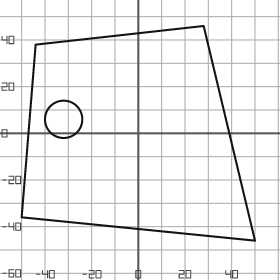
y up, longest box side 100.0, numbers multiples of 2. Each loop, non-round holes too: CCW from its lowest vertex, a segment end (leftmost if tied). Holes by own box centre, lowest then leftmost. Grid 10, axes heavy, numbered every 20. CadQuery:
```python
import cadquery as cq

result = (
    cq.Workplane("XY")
    .moveTo(50.0, -46.0)
    .lineTo(28.0, 46.0)
    .lineTo(-44.0, 38.0)
    .lineTo(-50.0, -36.0)
    .close()
    .moveTo(-32.0, 6.0)
    .circle(8.0)
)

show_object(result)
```